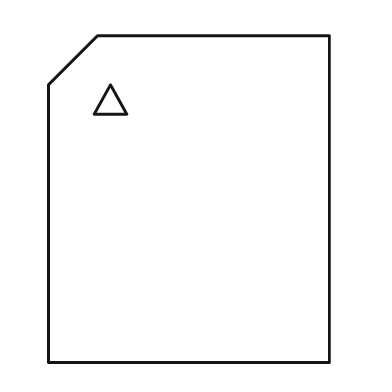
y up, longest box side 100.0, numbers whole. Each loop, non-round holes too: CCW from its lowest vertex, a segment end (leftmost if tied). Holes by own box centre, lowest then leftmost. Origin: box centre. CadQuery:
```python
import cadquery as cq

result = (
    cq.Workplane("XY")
    .moveTo(-43.0, -50.0)
    .lineTo(43.0, -50.0)
    .lineTo(43.0, 50.0)
    .lineTo(-28.0, 50.0)
    .lineTo(-43.0, 35.0)
    .close()
    .moveTo(-29.0, 26.0)
    .lineTo(-19.0, 26.0)
    .lineTo(-24.0, 35.0)
    .close()
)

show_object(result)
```